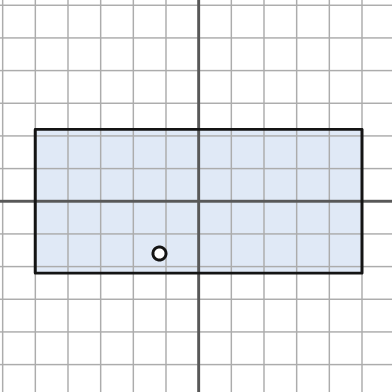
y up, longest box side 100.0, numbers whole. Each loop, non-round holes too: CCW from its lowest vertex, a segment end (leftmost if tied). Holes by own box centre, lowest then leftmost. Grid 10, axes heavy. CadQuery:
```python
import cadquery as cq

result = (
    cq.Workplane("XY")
    .moveTo(-50.0, -22.0)
    .lineTo(50.0, -22.0)
    .lineTo(50.0, 22.0)
    .lineTo(-50.0, 22.0)
    .close()
    .moveTo(-12.0, -16.0)
    .circle(2.0)
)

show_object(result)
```